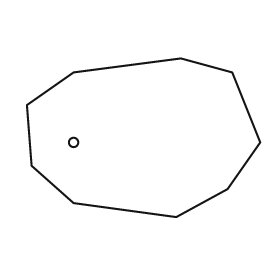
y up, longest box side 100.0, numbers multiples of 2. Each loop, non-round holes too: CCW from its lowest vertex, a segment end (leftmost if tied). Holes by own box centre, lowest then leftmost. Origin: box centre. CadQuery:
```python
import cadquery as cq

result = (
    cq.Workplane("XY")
    .moveTo(14.0, -34.0)
    .lineTo(36.0, -22.0)
    .lineTo(50.0, -2.0)
    .lineTo(38.0, 28.0)
    .lineTo(16.0, 34.0)
    .lineTo(-30.0, 28.0)
    .lineTo(-50.0, 14.0)
    .lineTo(-48.0, -12.0)
    .lineTo(-30.0, -28.0)
    .close()
    .moveTo(-30.0, -2.0)
    .circle(2.0)
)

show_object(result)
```